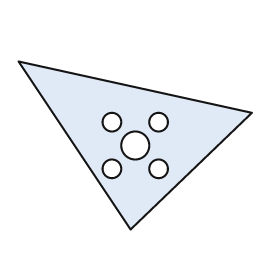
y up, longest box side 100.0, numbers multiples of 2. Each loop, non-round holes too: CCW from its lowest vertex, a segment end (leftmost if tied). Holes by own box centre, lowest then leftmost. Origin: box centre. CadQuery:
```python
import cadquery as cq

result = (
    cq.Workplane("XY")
    .moveTo(-2.0, -36.0)
    .lineTo(50.0, 14.0)
    .lineTo(-50.0, 36.0)
    .close()
    .moveTo(-10.0, -10.0)
    .circle(4.0)
    .moveTo(10.0, -10.0)
    .circle(4.0)
    .moveTo(0.0, 0.0)
    .circle(6.0)
    .moveTo(-10.0, 10.0)
    .circle(4.0)
    .moveTo(10.0, 10.0)
    .circle(4.0)
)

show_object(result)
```